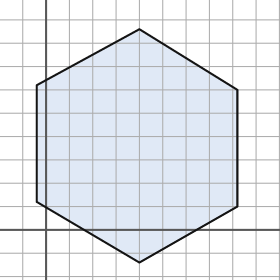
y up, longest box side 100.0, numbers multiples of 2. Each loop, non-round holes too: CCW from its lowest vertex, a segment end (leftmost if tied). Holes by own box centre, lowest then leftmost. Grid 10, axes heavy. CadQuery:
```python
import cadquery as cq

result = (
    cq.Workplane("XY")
    .moveTo(40.0, -14.0)
    .lineTo(82.0, 10.0)
    .lineTo(82.0, 60.0)
    .lineTo(40.0, 86.0)
    .lineTo(-4.0, 62.0)
    .lineTo(-4.0, 12.0)
    .close()
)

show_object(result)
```